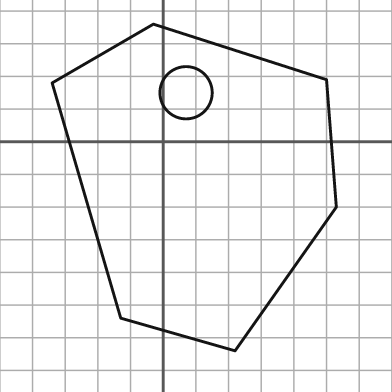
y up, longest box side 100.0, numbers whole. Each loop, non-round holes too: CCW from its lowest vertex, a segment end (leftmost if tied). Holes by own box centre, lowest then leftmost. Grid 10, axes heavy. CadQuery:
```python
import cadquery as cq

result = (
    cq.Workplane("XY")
    .moveTo(22.0, -64.0)
    .lineTo(53.0, -20.0)
    .lineTo(50.0, 19.0)
    .lineTo(-3.0, 36.0)
    .lineTo(-34.0, 18.0)
    .lineTo(-13.0, -54.0)
    .close()
    .moveTo(7.0, 15.0)
    .circle(8.0)
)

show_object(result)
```